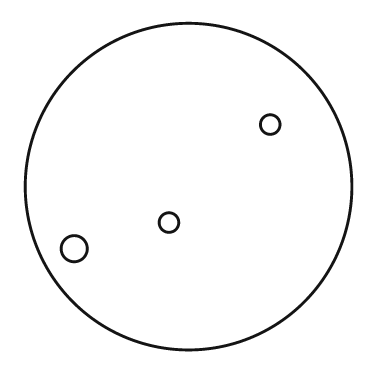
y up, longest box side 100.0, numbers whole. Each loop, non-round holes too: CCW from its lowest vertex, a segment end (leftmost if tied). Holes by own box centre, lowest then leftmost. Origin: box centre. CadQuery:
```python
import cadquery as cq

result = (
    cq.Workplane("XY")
    .moveTo(0.0, 0.0)
    .circle(50.0)
    .moveTo(-35.0, -19.0)
    .circle(4.0)
    .moveTo(-6.0, -11.0)
    .circle(3.0)
    .moveTo(25.0, 19.0)
    .circle(3.0)
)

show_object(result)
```